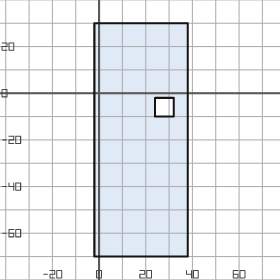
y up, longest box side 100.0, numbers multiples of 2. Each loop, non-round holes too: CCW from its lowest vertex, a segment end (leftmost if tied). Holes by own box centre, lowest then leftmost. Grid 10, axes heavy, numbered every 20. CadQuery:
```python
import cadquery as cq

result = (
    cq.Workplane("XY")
    .moveTo(-2.0, -70.0)
    .lineTo(38.0, -70.0)
    .lineTo(38.0, 30.0)
    .lineTo(-2.0, 30.0)
    .close()
    .moveTo(24.0, -10.0)
    .lineTo(32.0, -10.0)
    .lineTo(32.0, -2.0)
    .lineTo(24.0, -2.0)
    .close()
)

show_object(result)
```